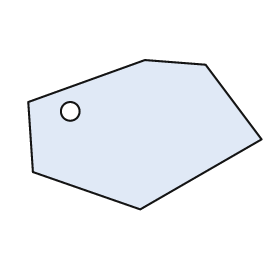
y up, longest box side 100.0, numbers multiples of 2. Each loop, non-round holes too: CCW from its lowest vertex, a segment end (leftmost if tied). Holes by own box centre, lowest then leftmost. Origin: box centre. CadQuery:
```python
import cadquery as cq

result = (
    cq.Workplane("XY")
    .moveTo(-2.0, -32.0)
    .lineTo(50.0, -2.0)
    .lineTo(26.0, 30.0)
    .lineTo(0.0, 32.0)
    .lineTo(-50.0, 14.0)
    .lineTo(-48.0, -16.0)
    .close()
    .moveTo(-32.0, 10.0)
    .circle(4.0)
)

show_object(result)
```